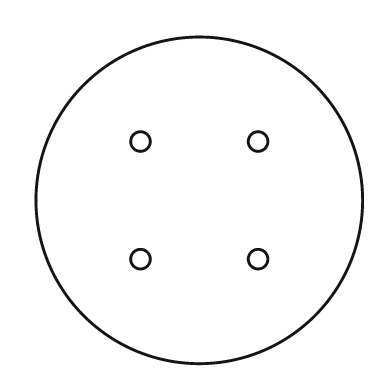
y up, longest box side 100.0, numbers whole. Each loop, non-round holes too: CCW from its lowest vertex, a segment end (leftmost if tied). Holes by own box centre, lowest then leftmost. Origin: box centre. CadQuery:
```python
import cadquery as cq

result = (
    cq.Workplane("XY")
    .moveTo(0.0, 0.0)
    .circle(50.0)
    .moveTo(-18.0, -18.0)
    .circle(3.0)
    .moveTo(18.0, -18.0)
    .circle(3.0)
    .moveTo(-18.0, 18.0)
    .circle(3.0)
    .moveTo(18.0, 18.0)
    .circle(3.0)
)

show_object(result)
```